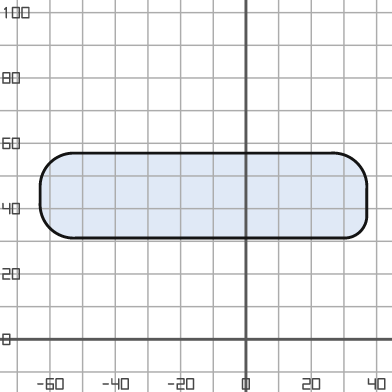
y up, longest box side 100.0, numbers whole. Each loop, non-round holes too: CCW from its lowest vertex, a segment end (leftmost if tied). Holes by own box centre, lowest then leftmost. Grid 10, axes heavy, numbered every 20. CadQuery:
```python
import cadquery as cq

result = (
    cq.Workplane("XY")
    .moveTo(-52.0, 31.0)
    .lineTo(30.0, 31.0)
    .threePointArc((35.0, 33.0), (37.0, 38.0))
    .lineTo(37.0, 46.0)
    .threePointArc((34.0, 54.0), (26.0, 57.0))
    .lineTo(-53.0, 57.0)
    .threePointArc((-60.0, 54.0), (-63.0, 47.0))
    .lineTo(-63.0, 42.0)
    .threePointArc((-60.0, 34.0), (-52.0, 31.0))
    .close()
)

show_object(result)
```